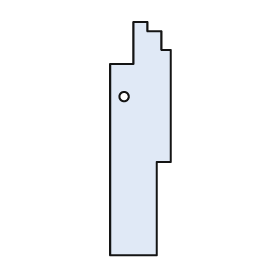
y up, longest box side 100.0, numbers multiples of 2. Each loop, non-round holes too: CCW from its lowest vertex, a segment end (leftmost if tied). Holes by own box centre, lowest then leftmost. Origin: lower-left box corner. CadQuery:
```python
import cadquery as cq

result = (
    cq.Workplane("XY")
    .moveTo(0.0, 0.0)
    .lineTo(20.0, 0.0)
    .lineTo(20.0, 40.0)
    .lineTo(26.0, 40.0)
    .lineTo(26.0, 88.0)
    .lineTo(22.0, 88.0)
    .lineTo(22.0, 96.0)
    .lineTo(16.0, 96.0)
    .lineTo(16.0, 100.0)
    .lineTo(10.0, 100.0)
    .lineTo(10.0, 82.0)
    .lineTo(0.0, 82.0)
    .close()
    .moveTo(6.0, 68.0)
    .circle(2.0)
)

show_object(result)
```